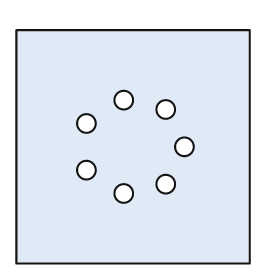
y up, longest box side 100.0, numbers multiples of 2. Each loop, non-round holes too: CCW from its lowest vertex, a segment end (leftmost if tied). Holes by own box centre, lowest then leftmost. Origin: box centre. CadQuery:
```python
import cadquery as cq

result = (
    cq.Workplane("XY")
    .moveTo(-50.0, -50.0)
    .lineTo(50.0, -50.0)
    .lineTo(50.0, 50.0)
    .lineTo(-50.0, 50.0)
    .close()
    .moveTo(-4.0, -20.0)
    .circle(4.0)
    .moveTo(14.0, -16.0)
    .circle(4.0)
    .moveTo(-20.0, -10.0)
    .circle(4.0)
    .moveTo(22.0, 0.0)
    .circle(4.0)
    .moveTo(-20.0, 10.0)
    .circle(4.0)
    .moveTo(14.0, 16.0)
    .circle(4.0)
    .moveTo(-4.0, 20.0)
    .circle(4.0)
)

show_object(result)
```